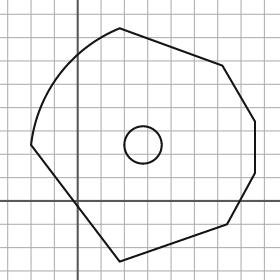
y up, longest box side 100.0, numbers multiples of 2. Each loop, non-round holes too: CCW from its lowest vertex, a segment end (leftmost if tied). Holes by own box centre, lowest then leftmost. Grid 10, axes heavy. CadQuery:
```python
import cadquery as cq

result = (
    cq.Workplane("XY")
    .moveTo(18.0, -26.0)
    .lineTo(64.0, -10.0)
    .lineTo(76.0, 12.0)
    .lineTo(76.0, 34.0)
    .lineTo(62.0, 58.0)
    .lineTo(18.0, 74.0)
    .threePointArc((-8.0, 54.0), (-20.0, 24.0))
    .close()
    .moveTo(28.0, 24.0)
    .circle(8.0)
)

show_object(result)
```